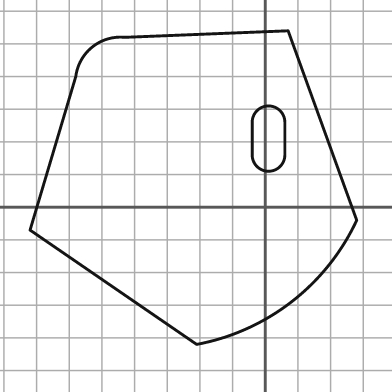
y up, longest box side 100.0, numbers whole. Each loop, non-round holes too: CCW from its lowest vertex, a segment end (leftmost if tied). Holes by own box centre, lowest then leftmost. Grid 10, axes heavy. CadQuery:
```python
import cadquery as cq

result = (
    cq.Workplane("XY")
    .moveTo(-21.0, -42.0)
    .threePointArc((8.0, -29.0), (28.0, -4.0))
    .lineTo(7.0, 54.0)
    .lineTo(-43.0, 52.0)
    .threePointArc((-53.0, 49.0), (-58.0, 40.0))
    .lineTo(-72.0, -7.0)
    .close()
    .moveTo(-4.0, 16.0)
    .threePointArc((1.0, 11.0), (6.0, 16.0))
    .lineTo(6.0, 26.0)
    .threePointArc((1.0, 31.0), (-4.0, 26.0))
    .close()
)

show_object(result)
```